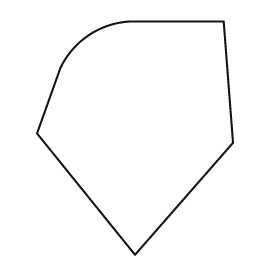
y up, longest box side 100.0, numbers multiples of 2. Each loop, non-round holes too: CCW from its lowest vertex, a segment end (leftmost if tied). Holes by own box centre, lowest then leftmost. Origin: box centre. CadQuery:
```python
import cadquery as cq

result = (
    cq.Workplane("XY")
    .moveTo(0.0, -50.0)
    .lineTo(42.0, -2.0)
    .lineTo(38.0, 50.0)
    .lineTo(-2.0, 50.0)
    .threePointArc((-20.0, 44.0), (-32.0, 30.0))
    .lineTo(-42.0, 2.0)
    .close()
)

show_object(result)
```